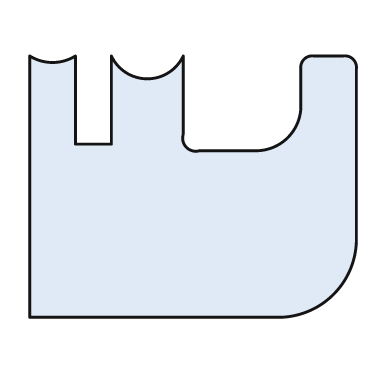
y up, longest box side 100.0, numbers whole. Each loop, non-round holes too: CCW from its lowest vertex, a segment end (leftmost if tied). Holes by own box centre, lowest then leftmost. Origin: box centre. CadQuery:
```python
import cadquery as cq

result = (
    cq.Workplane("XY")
    .moveTo(-50.0, -40.0)
    .lineTo(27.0, -40.0)
    .threePointArc((43.0, -33.0), (50.0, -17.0))
    .lineTo(50.0, 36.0)
    .threePointArc((49.0, 39.0), (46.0, 40.0))
    .lineTo(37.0, 40.0)
    .threePointArc((34.0, 39.0), (33.0, 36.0))
    .lineTo(33.0, 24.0)
    .threePointArc((29.0, 15.0), (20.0, 11.0))
    .lineTo(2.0, 11.0)
    .threePointArc((-2.0, 12.0), (-3.0, 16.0))
    .lineTo(-3.0, 40.0)
    .threePointArc((-14.0, 33.0), (-25.0, 40.0))
    .lineTo(-25.0, 13.0)
    .lineTo(-36.0, 13.0)
    .lineTo(-36.0, 40.0)
    .threePointArc((-43.0, 38.0), (-50.0, 40.0))
    .close()
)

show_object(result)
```